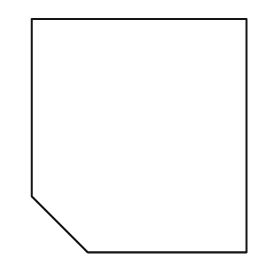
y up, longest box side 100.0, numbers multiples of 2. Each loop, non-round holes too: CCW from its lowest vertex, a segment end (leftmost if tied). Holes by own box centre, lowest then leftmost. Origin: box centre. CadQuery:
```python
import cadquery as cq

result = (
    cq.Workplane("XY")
    .moveTo(-22.0, -50.0)
    .lineTo(46.0, -50.0)
    .lineTo(46.0, 50.0)
    .lineTo(-46.0, 50.0)
    .lineTo(-46.0, -26.0)
    .close()
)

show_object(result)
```